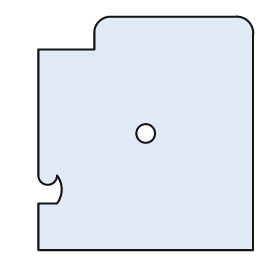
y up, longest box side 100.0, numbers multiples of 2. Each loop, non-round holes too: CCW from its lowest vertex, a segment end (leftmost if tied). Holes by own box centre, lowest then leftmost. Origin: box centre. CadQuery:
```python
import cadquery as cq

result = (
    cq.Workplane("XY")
    .moveTo(-46.0, -50.0)
    .lineTo(46.0, -50.0)
    .lineTo(46.0, 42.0)
    .threePointArc((44.0, 48.0), (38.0, 50.0))
    .lineTo(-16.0, 50.0)
    .threePointArc((-20.0, 48.0), (-22.0, 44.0))
    .lineTo(-22.0, 36.0)
    .lineTo(-46.0, 36.0)
    .lineTo(-46.0, -18.0)
    .threePointArc((-42.0, -22.0), (-38.0, -18.0))
    .threePointArc((-36.0, -24.0), (-38.0, -30.0))
    .lineTo(-46.0, -30.0)
    .close()
    .moveTo(0.0, 0.0)
    .circle(4.0)
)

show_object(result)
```